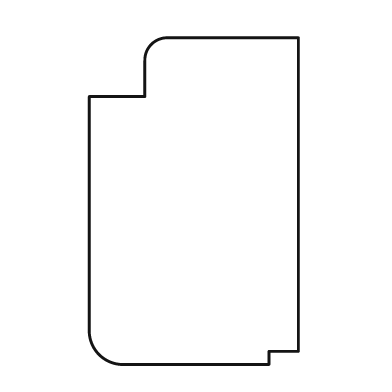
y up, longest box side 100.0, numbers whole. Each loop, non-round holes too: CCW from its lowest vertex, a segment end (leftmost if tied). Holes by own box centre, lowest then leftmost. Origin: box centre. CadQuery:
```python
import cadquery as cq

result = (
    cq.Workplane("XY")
    .moveTo(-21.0, -50.0)
    .lineTo(23.0, -50.0)
    .lineTo(23.0, -46.0)
    .lineTo(32.0, -46.0)
    .lineTo(32.0, 50.0)
    .lineTo(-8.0, 50.0)
    .threePointArc((-13.0, 48.0), (-15.0, 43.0))
    .lineTo(-15.0, 32.0)
    .lineTo(-32.0, 32.0)
    .lineTo(-32.0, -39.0)
    .threePointArc((-29.0, -47.0), (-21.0, -50.0))
    .close()
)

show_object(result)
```